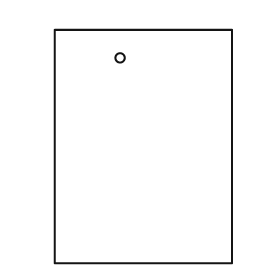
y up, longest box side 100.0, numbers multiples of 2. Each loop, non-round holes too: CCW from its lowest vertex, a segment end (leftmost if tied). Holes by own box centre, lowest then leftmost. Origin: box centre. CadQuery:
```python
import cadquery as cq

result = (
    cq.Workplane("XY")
    .moveTo(-38.0, -50.0)
    .lineTo(38.0, -50.0)
    .lineTo(38.0, 50.0)
    .lineTo(-38.0, 50.0)
    .close()
    .moveTo(-10.0, 38.0)
    .circle(2.0)
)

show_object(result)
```